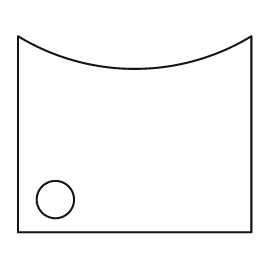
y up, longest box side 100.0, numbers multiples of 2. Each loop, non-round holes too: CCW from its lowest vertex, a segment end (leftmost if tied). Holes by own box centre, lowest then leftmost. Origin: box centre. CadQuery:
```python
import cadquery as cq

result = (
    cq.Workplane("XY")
    .moveTo(-50.0, -42.0)
    .lineTo(50.0, -42.0)
    .lineTo(50.0, 42.0)
    .threePointArc((0.0, 28.0), (-50.0, 42.0))
    .close()
    .moveTo(-34.0, -28.0)
    .circle(8.0)
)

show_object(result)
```